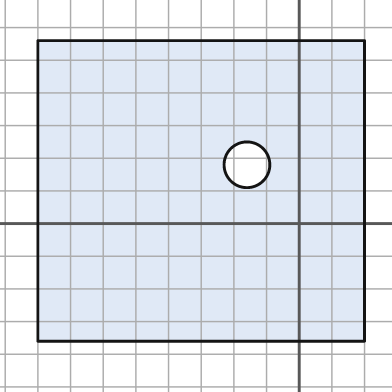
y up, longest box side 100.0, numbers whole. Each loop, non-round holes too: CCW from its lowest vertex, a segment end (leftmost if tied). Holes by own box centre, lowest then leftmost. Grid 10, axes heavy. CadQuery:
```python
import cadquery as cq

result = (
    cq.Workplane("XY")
    .moveTo(-80.0, -36.0)
    .lineTo(20.0, -36.0)
    .lineTo(20.0, 56.0)
    .lineTo(-80.0, 56.0)
    .close()
    .moveTo(-16.0, 18.0)
    .circle(7.0)
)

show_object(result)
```